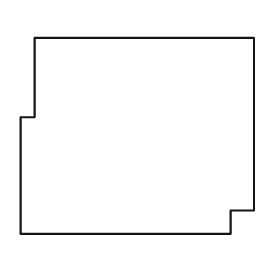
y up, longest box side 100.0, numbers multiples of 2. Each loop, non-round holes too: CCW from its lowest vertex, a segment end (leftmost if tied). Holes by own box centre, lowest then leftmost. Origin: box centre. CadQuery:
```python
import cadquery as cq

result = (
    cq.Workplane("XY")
    .moveTo(-50.0, -42.0)
    .lineTo(40.0, -42.0)
    .lineTo(40.0, -32.0)
    .lineTo(50.0, -32.0)
    .lineTo(50.0, 42.0)
    .lineTo(-44.0, 42.0)
    .lineTo(-44.0, 8.0)
    .lineTo(-50.0, 8.0)
    .close()
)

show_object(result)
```